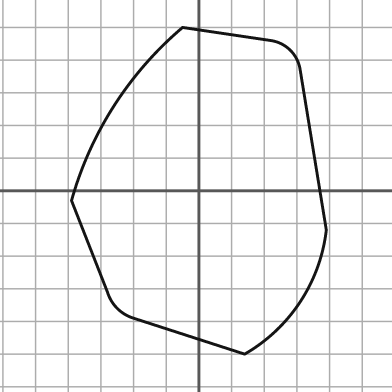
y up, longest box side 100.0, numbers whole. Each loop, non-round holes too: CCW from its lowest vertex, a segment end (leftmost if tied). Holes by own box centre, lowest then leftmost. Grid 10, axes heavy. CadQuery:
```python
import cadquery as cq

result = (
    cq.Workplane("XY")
    .moveTo(14.0, -50.0)
    .threePointArc((31.0, -34.0), (39.0, -12.0))
    .lineTo(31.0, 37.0)
    .threePointArc((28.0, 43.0), (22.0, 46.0))
    .lineTo(-5.0, 50.0)
    .threePointArc((-26.0, 26.0), (-39.0, -3.0))
    .lineTo(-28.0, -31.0)
    .threePointArc((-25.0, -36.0), (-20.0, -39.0))
    .close()
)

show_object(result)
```